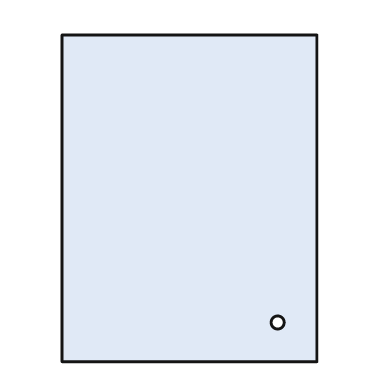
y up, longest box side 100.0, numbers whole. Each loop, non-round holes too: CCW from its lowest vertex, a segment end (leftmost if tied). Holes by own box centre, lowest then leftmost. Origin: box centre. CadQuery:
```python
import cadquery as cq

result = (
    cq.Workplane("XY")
    .moveTo(-39.0, -50.0)
    .lineTo(39.0, -50.0)
    .lineTo(39.0, 50.0)
    .lineTo(-39.0, 50.0)
    .close()
    .moveTo(27.0, -38.0)
    .circle(2.0)
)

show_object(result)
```